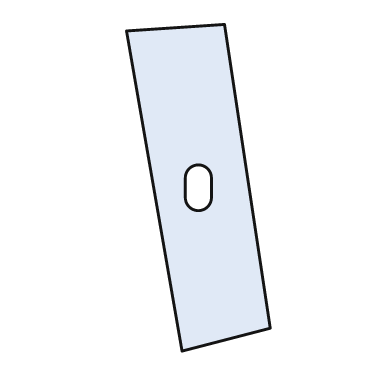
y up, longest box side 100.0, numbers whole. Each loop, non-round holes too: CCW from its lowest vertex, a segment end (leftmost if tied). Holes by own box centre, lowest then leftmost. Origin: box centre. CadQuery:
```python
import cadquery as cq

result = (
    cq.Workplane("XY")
    .moveTo(-5.0, -50.0)
    .lineTo(22.0, -43.0)
    .lineTo(8.0, 50.0)
    .lineTo(-22.0, 48.0)
    .close()
    .moveTo(-4.0, -3.0)
    .threePointArc((0.0, -7.0), (4.0, -3.0))
    .lineTo(4.0, 3.0)
    .threePointArc((0.0, 7.0), (-4.0, 3.0))
    .close()
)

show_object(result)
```